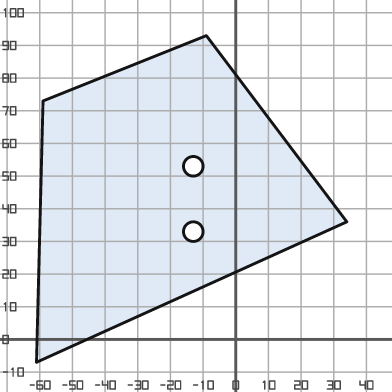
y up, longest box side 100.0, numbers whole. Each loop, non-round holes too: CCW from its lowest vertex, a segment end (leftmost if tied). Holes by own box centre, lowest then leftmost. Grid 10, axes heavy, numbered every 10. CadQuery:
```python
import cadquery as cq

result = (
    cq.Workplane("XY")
    .moveTo(-61.0, -7.0)
    .lineTo(34.0, 36.0)
    .lineTo(-9.0, 93.0)
    .lineTo(-59.0, 73.0)
    .close()
    .moveTo(-13.0, 33.0)
    .circle(3.0)
    .moveTo(-13.0, 53.0)
    .circle(3.0)
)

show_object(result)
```